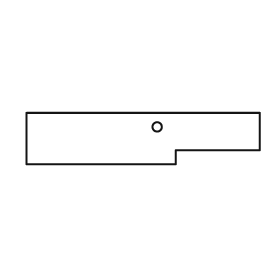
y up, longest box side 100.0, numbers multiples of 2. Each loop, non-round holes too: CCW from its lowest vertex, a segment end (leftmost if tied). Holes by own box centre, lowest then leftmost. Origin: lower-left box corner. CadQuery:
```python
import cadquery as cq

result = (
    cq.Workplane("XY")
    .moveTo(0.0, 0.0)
    .lineTo(64.0, 0.0)
    .lineTo(64.0, 6.0)
    .lineTo(100.0, 6.0)
    .lineTo(100.0, 22.0)
    .lineTo(0.0, 22.0)
    .close()
    .moveTo(56.0, 16.0)
    .circle(2.0)
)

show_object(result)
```